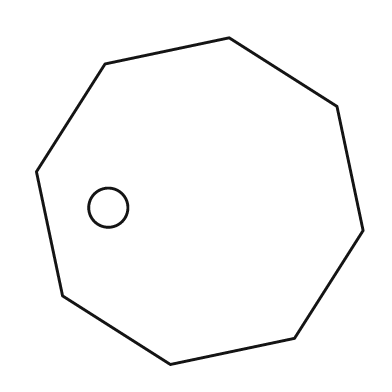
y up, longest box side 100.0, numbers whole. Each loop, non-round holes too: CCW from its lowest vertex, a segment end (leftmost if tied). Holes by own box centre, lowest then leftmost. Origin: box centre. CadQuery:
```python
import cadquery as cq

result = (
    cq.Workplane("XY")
    .moveTo(-9.0, -50.0)
    .lineTo(29.0, -42.0)
    .lineTo(50.0, -9.0)
    .lineTo(42.0, 29.0)
    .lineTo(9.0, 50.0)
    .lineTo(-29.0, 42.0)
    .lineTo(-50.0, 9.0)
    .lineTo(-42.0, -29.0)
    .close()
    .moveTo(-28.0, -2.0)
    .circle(6.0)
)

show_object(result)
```